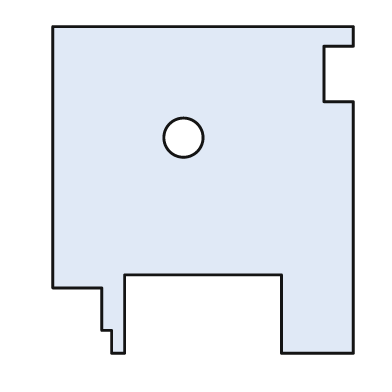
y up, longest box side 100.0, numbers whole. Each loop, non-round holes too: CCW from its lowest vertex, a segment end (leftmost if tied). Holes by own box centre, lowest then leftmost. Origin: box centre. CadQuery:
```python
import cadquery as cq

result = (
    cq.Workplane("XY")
    .moveTo(-28.0, -50.0)
    .lineTo(-24.0, -50.0)
    .lineTo(-24.0, -26.0)
    .lineTo(24.0, -26.0)
    .lineTo(24.0, -50.0)
    .lineTo(46.0, -50.0)
    .lineTo(46.0, 27.0)
    .lineTo(37.0, 27.0)
    .lineTo(37.0, 44.0)
    .lineTo(46.0, 44.0)
    .lineTo(46.0, 50.0)
    .lineTo(-46.0, 50.0)
    .lineTo(-46.0, -30.0)
    .lineTo(-31.0, -30.0)
    .lineTo(-31.0, -43.0)
    .lineTo(-28.0, -43.0)
    .close()
    .moveTo(-6.0, 16.0)
    .circle(6.0)
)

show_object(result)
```